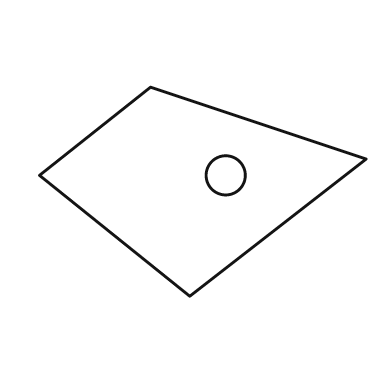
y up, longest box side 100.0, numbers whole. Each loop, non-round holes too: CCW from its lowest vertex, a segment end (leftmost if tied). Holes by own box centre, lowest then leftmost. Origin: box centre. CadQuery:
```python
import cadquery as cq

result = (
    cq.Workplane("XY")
    .moveTo(-4.0, -32.0)
    .lineTo(50.0, 10.0)
    .lineTo(-16.0, 32.0)
    .lineTo(-50.0, 5.0)
    .close()
    .moveTo(7.0, 5.0)
    .circle(6.0)
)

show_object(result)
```